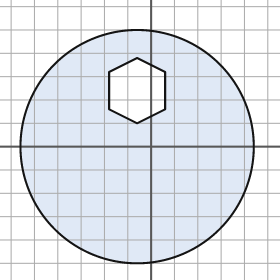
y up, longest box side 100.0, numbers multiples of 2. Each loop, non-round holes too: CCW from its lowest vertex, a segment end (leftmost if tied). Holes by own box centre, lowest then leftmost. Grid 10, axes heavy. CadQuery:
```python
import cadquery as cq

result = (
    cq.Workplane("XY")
    .moveTo(-6.0, 0.0)
    .circle(50.0)
    .moveTo(-6.0, 10.0)
    .lineTo(6.0, 16.0)
    .lineTo(6.0, 32.0)
    .lineTo(-6.0, 38.0)
    .lineTo(-18.0, 32.0)
    .lineTo(-18.0, 16.0)
    .close()
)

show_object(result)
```